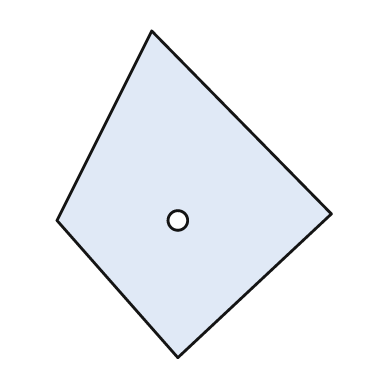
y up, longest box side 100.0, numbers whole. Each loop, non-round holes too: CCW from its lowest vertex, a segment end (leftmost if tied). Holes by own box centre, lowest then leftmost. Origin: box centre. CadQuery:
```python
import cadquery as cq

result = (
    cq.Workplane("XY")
    .moveTo(-5.0, -50.0)
    .lineTo(42.0, -6.0)
    .lineTo(-13.0, 50.0)
    .lineTo(-42.0, -8.0)
    .close()
    .moveTo(-5.0, -8.0)
    .circle(3.0)
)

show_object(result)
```